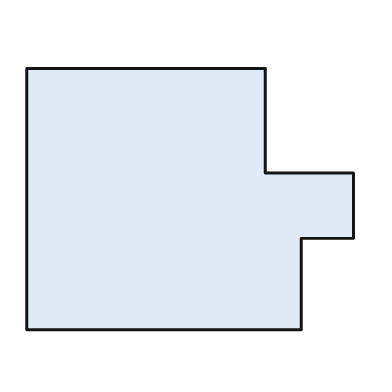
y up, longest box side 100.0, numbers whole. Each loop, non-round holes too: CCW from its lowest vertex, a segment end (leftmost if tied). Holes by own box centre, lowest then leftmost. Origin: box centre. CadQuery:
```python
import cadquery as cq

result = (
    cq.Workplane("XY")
    .moveTo(-50.0, -40.0)
    .lineTo(34.0, -40.0)
    .lineTo(34.0, -12.0)
    .lineTo(50.0, -12.0)
    .lineTo(50.0, 8.0)
    .lineTo(23.0, 8.0)
    .lineTo(23.0, 40.0)
    .lineTo(-50.0, 40.0)
    .close()
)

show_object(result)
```